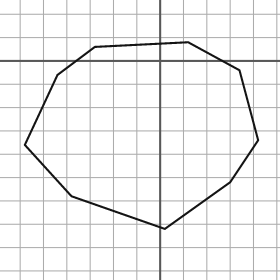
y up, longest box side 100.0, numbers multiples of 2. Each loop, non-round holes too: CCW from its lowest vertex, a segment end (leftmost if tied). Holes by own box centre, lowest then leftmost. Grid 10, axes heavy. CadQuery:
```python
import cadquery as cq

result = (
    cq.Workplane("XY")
    .moveTo(2.0, -72.0)
    .lineTo(30.0, -52.0)
    .lineTo(42.0, -34.0)
    .lineTo(34.0, -4.0)
    .lineTo(12.0, 8.0)
    .lineTo(-28.0, 6.0)
    .lineTo(-44.0, -6.0)
    .lineTo(-58.0, -36.0)
    .lineTo(-38.0, -58.0)
    .close()
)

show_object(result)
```